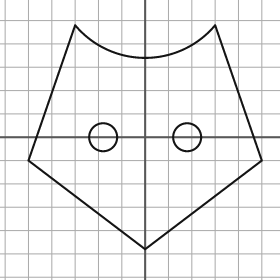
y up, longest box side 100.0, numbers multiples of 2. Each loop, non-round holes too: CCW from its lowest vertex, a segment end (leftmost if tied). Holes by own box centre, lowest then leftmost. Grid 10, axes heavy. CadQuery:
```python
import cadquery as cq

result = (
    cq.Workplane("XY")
    .moveTo(0.0, -48.0)
    .lineTo(50.0, -10.0)
    .lineTo(30.0, 48.0)
    .threePointArc((0.0, 34.0), (-30.0, 48.0))
    .lineTo(-50.0, -10.0)
    .close()
    .moveTo(-18.0, 0.0)
    .circle(6.0)
    .moveTo(18.0, 0.0)
    .circle(6.0)
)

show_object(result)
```